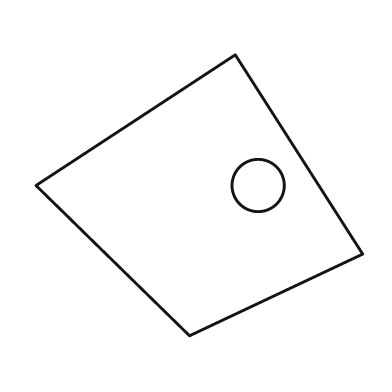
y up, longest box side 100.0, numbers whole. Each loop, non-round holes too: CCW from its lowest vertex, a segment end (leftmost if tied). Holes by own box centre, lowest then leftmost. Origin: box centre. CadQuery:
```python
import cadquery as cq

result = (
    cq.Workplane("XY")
    .moveTo(-3.0, -43.0)
    .lineTo(50.0, -18.0)
    .lineTo(11.0, 43.0)
    .lineTo(-50.0, 3.0)
    .close()
    .moveTo(18.0, 3.0)
    .circle(8.0)
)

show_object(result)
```